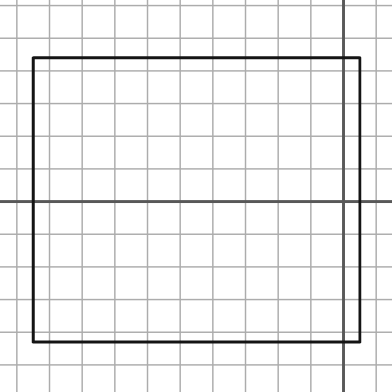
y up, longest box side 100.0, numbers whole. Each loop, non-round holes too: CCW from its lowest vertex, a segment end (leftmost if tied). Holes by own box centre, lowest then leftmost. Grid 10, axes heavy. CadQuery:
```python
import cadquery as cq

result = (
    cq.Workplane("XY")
    .moveTo(-95.0, -43.0)
    .lineTo(5.0, -43.0)
    .lineTo(5.0, 44.0)
    .lineTo(-95.0, 44.0)
    .close()
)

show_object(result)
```